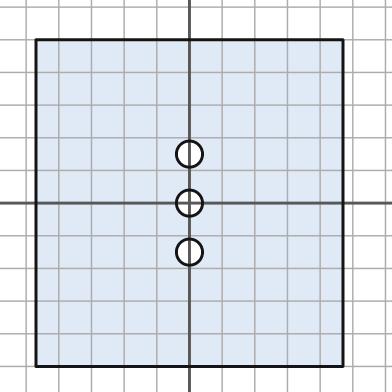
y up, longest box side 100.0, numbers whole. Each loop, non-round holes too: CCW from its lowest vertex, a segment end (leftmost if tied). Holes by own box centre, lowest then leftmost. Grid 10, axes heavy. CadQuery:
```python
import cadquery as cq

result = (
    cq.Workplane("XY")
    .moveTo(-47.0, -50.0)
    .lineTo(47.0, -50.0)
    .lineTo(47.0, 50.0)
    .lineTo(-47.0, 50.0)
    .close()
    .moveTo(0.0, -15.0)
    .circle(4.0)
    .moveTo(0.0, 0.0)
    .circle(4.0)
    .moveTo(0.0, 15.0)
    .circle(4.0)
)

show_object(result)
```